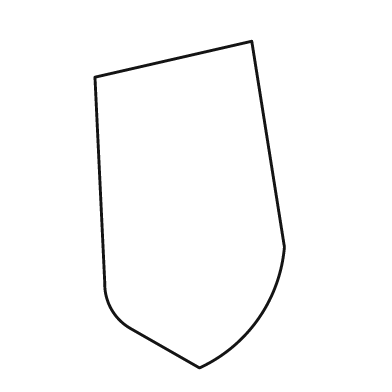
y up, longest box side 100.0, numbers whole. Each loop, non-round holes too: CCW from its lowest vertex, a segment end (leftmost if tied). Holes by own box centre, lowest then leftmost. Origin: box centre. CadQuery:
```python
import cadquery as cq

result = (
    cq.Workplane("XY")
    .moveTo(3.0, -50.0)
    .threePointArc((21.0, -35.0), (29.0, -13.0))
    .lineTo(19.0, 50.0)
    .lineTo(-29.0, 39.0)
    .lineTo(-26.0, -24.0)
    .threePointArc((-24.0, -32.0), (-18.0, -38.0))
    .close()
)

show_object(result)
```